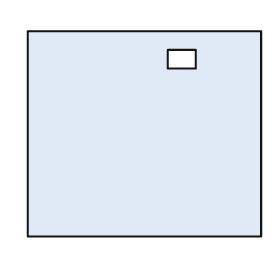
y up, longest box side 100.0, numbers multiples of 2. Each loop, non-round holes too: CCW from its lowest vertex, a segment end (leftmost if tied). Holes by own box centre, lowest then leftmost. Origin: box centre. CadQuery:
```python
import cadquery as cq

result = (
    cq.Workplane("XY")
    .moveTo(-50.0, -44.0)
    .lineTo(50.0, -44.0)
    .lineTo(50.0, 44.0)
    .lineTo(-50.0, 44.0)
    .close()
    .moveTo(10.0, 28.0)
    .lineTo(22.0, 28.0)
    .lineTo(22.0, 36.0)
    .lineTo(10.0, 36.0)
    .close()
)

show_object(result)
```